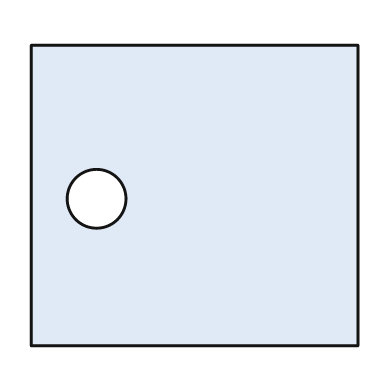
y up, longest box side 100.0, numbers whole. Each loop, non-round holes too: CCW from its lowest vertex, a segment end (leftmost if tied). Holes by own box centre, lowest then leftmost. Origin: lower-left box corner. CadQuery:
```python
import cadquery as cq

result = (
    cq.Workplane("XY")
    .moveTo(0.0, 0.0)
    .lineTo(100.0, 0.0)
    .lineTo(100.0, 92.0)
    .lineTo(0.0, 92.0)
    .close()
    .moveTo(20.0, 45.0)
    .circle(9.0)
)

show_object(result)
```